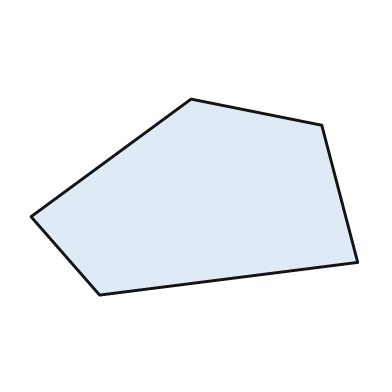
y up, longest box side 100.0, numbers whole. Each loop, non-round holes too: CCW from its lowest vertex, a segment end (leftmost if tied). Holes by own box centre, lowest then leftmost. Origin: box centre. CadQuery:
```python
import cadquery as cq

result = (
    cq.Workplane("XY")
    .moveTo(-29.0, -30.0)
    .lineTo(50.0, -20.0)
    .lineTo(39.0, 22.0)
    .lineTo(-1.0, 30.0)
    .lineTo(-50.0, -6.0)
    .close()
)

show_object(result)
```